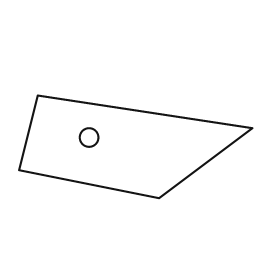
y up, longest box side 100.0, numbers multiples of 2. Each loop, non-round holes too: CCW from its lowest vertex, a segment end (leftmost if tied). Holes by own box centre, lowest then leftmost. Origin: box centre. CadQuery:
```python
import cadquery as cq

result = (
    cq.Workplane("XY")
    .moveTo(10.0, -22.0)
    .lineTo(50.0, 8.0)
    .lineTo(-42.0, 22.0)
    .lineTo(-50.0, -10.0)
    .close()
    .moveTo(-20.0, 4.0)
    .circle(4.0)
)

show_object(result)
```